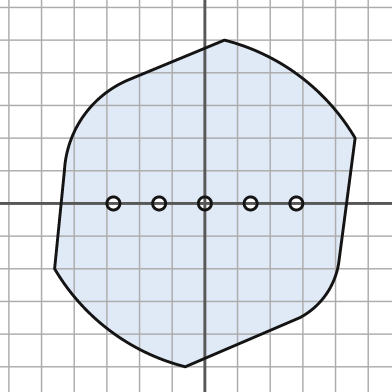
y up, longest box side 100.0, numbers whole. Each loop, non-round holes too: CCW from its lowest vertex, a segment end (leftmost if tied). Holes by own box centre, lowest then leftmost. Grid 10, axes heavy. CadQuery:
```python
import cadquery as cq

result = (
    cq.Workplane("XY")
    .moveTo(-6.0, -50.0)
    .lineTo(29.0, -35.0)
    .threePointArc((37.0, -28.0), (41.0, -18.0))
    .lineTo(46.0, 20.0)
    .threePointArc((29.0, 39.0), (6.0, 50.0))
    .lineTo(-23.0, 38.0)
    .threePointArc((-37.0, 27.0), (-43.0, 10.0))
    .lineTo(-46.0, -20.0)
    .threePointArc((-29.0, -39.0), (-6.0, -50.0))
    .close()
    .moveTo(-28.0, 0.0)
    .circle(2.0)
    .moveTo(-14.0, 0.0)
    .circle(2.0)
    .moveTo(0.0, 0.0)
    .circle(2.0)
    .moveTo(14.0, 0.0)
    .circle(2.0)
    .moveTo(28.0, 0.0)
    .circle(2.0)
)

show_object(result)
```